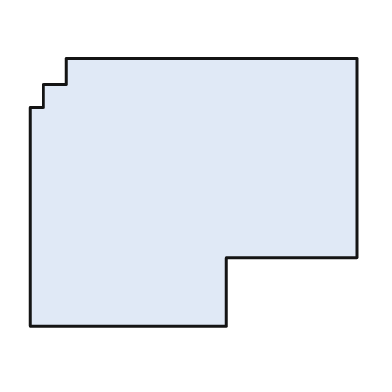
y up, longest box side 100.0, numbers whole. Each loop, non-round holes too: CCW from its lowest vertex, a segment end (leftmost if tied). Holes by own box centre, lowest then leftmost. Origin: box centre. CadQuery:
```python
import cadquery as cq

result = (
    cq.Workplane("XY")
    .moveTo(-50.0, -41.0)
    .lineTo(10.0, -41.0)
    .lineTo(10.0, -20.0)
    .lineTo(50.0, -20.0)
    .lineTo(50.0, 41.0)
    .lineTo(-39.0, 41.0)
    .lineTo(-39.0, 33.0)
    .lineTo(-46.0, 33.0)
    .lineTo(-46.0, 26.0)
    .lineTo(-50.0, 26.0)
    .close()
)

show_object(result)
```